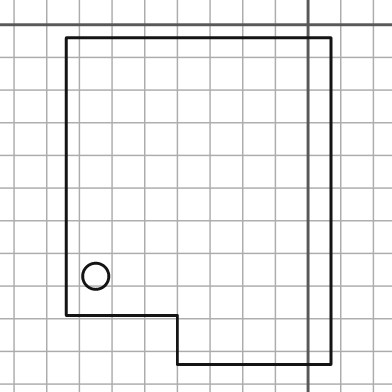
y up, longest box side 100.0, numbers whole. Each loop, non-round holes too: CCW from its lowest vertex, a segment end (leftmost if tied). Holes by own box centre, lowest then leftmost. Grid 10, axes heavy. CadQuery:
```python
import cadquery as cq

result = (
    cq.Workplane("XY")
    .moveTo(-40.0, -104.0)
    .lineTo(7.0, -104.0)
    .lineTo(7.0, -4.0)
    .lineTo(-74.0, -4.0)
    .lineTo(-74.0, -89.0)
    .lineTo(-40.0, -89.0)
    .close()
    .moveTo(-65.0, -77.0)
    .circle(4.0)
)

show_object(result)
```